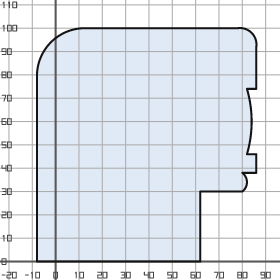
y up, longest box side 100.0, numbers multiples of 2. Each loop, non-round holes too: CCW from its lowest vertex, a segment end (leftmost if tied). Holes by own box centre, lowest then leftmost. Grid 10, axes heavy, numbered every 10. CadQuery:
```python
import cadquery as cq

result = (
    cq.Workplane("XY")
    .moveTo(-8.0, 0.0)
    .lineTo(62.0, 0.0)
    .lineTo(62.0, 30.0)
    .lineTo(80.0, 30.0)
    .threePointArc((82.0, 34.0), (80.0, 38.0))
    .lineTo(86.0, 38.0)
    .lineTo(86.0, 46.0)
    .lineTo(82.0, 46.0)
    .threePointArc((84.0, 60.0), (82.0, 74.0))
    .lineTo(86.0, 74.0)
    .lineTo(86.0, 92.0)
    .threePointArc((84.0, 98.0), (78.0, 100.0))
    .lineTo(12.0, 100.0)
    .threePointArc((-2.0, 94.0), (-8.0, 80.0))
    .close()
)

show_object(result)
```